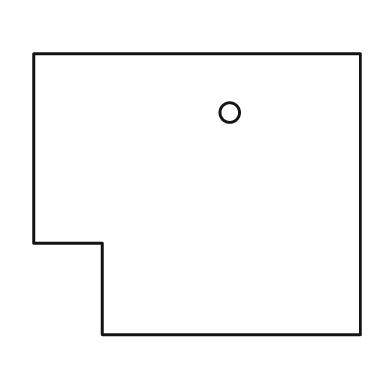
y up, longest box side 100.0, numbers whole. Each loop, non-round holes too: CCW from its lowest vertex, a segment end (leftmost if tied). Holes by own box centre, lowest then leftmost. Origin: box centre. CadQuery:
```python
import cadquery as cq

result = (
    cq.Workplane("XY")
    .moveTo(-29.0, -43.0)
    .lineTo(50.0, -43.0)
    .lineTo(50.0, 43.0)
    .lineTo(-50.0, 43.0)
    .lineTo(-50.0, -15.0)
    .lineTo(-29.0, -15.0)
    .close()
    .moveTo(10.0, 25.0)
    .circle(3.0)
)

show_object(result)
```